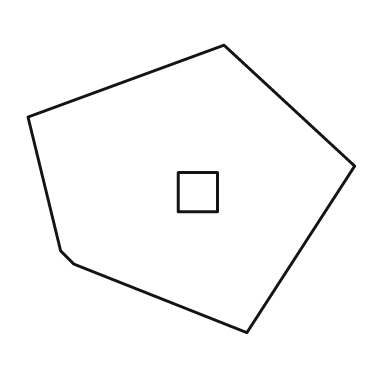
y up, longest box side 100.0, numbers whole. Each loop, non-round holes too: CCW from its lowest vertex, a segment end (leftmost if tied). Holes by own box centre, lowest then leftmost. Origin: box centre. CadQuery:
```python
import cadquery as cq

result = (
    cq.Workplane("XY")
    .moveTo(17.0, -44.0)
    .lineTo(50.0, 7.0)
    .lineTo(10.0, 44.0)
    .lineTo(-50.0, 22.0)
    .lineTo(-40.0, -19.0)
    .lineTo(-36.0, -23.0)
    .close()
    .moveTo(-4.0, -7.0)
    .lineTo(8.0, -7.0)
    .lineTo(8.0, 5.0)
    .lineTo(-4.0, 5.0)
    .close()
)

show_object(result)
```